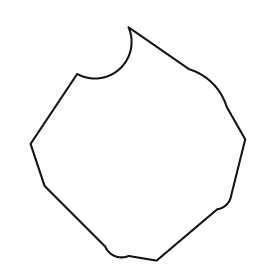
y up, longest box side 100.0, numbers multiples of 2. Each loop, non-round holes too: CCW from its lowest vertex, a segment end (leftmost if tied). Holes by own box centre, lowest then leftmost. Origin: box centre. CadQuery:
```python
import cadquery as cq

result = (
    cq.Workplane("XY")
    .moveTo(8.0, -50.0)
    .lineTo(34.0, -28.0)
    .threePointArc((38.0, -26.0), (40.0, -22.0))
    .lineTo(46.0, 2.0)
    .lineTo(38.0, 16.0)
    .threePointArc((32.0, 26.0), (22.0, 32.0))
    .lineTo(-4.0, 50.0)
    .threePointArc((-8.0, 32.0), (-26.0, 30.0))
    .lineTo(-46.0, 0.0)
    .lineTo(-40.0, -18.0)
    .lineTo(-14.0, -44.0)
    .threePointArc((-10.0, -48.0), (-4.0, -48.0))
    .close()
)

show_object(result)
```